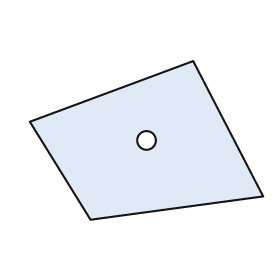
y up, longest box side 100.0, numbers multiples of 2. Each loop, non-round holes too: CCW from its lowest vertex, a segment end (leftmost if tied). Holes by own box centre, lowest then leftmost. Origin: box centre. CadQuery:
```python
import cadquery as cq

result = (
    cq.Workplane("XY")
    .moveTo(-24.0, -34.0)
    .lineTo(50.0, -24.0)
    .lineTo(20.0, 34.0)
    .lineTo(-50.0, 8.0)
    .close()
    .moveTo(0.0, 0.0)
    .circle(4.0)
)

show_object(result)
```